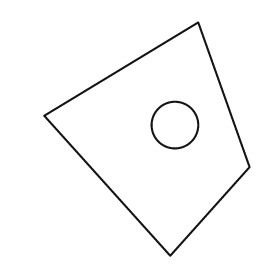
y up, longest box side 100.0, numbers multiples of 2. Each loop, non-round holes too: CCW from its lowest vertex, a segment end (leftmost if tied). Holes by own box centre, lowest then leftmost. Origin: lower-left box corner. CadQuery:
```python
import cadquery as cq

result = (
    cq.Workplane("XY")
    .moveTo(54.0, 0.0)
    .lineTo(88.0, 38.0)
    .lineTo(66.0, 100.0)
    .lineTo(0.0, 60.0)
    .close()
    .moveTo(56.0, 56.0)
    .circle(10.0)
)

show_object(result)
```